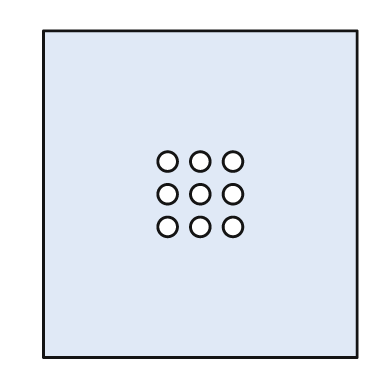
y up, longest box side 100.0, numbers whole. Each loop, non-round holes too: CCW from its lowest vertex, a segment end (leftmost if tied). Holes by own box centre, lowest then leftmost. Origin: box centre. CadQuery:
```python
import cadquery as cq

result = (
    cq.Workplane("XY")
    .moveTo(-48.0, -50.0)
    .lineTo(48.0, -50.0)
    .lineTo(48.0, 50.0)
    .lineTo(-48.0, 50.0)
    .close()
    .moveTo(-10.0, -10.0)
    .circle(3.0)
    .moveTo(0.0, -10.0)
    .circle(3.0)
    .moveTo(10.0, -10.0)
    .circle(3.0)
    .moveTo(-10.0, 0.0)
    .circle(3.0)
    .moveTo(0.0, 0.0)
    .circle(3.0)
    .moveTo(10.0, 0.0)
    .circle(3.0)
    .moveTo(-10.0, 10.0)
    .circle(3.0)
    .moveTo(0.0, 10.0)
    .circle(3.0)
    .moveTo(10.0, 10.0)
    .circle(3.0)
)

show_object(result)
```